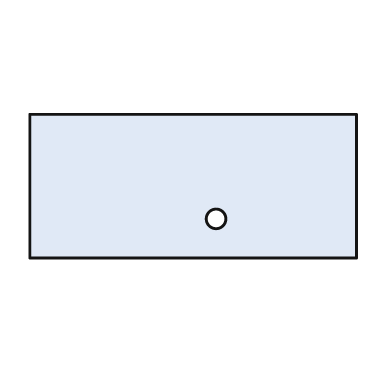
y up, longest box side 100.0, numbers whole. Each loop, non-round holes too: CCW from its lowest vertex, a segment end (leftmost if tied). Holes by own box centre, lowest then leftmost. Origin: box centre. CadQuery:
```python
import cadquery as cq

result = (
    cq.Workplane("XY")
    .moveTo(-50.0, -22.0)
    .lineTo(50.0, -22.0)
    .lineTo(50.0, 22.0)
    .lineTo(-50.0, 22.0)
    .close()
    .moveTo(7.0, -10.0)
    .circle(3.0)
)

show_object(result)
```